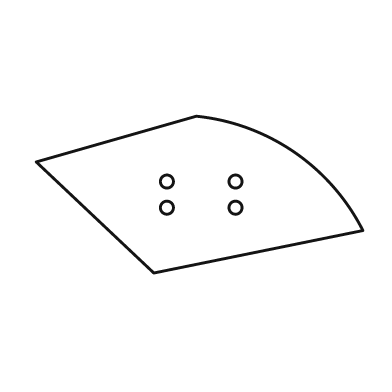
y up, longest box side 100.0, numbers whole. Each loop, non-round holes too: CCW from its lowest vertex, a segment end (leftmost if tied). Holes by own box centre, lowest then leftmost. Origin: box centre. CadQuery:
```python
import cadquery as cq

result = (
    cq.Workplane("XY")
    .moveTo(-14.0, -24.0)
    .lineTo(50.0, -11.0)
    .threePointArc((29.0, 13.0), (-1.0, 24.0))
    .lineTo(-50.0, 10.0)
    .close()
    .moveTo(-10.0, -4.0)
    .circle(2.0)
    .moveTo(11.0, -4.0)
    .circle(2.0)
    .moveTo(-10.0, 4.0)
    .circle(2.0)
    .moveTo(11.0, 4.0)
    .circle(2.0)
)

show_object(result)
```